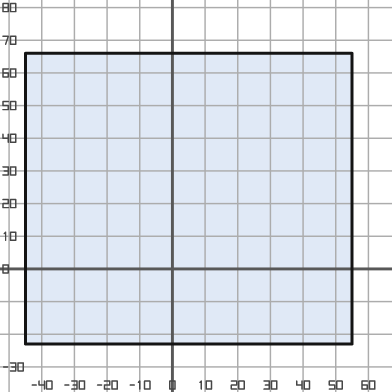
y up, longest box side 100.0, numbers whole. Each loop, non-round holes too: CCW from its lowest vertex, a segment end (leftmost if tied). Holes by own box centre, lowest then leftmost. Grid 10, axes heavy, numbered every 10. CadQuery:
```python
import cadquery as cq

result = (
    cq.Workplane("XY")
    .moveTo(-45.0, -23.0)
    .lineTo(55.0, -23.0)
    .lineTo(55.0, 66.0)
    .lineTo(-45.0, 66.0)
    .close()
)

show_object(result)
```